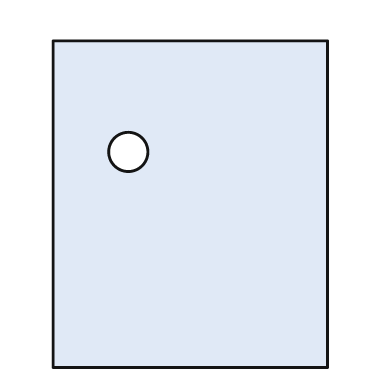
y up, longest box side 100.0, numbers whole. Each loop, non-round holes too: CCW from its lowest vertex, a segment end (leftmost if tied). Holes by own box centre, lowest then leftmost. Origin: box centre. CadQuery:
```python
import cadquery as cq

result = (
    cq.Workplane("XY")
    .moveTo(-42.0, -50.0)
    .lineTo(42.0, -50.0)
    .lineTo(42.0, 50.0)
    .lineTo(-42.0, 50.0)
    .close()
    .moveTo(-19.0, 16.0)
    .circle(6.0)
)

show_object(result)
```